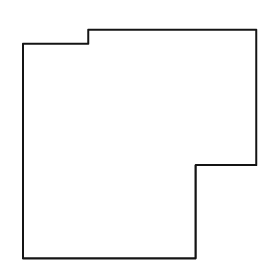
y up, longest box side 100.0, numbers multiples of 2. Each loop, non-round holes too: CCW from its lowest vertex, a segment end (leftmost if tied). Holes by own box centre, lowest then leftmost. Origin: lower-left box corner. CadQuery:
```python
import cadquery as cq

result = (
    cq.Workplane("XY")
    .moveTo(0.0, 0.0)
    .lineTo(74.0, 0.0)
    .lineTo(74.0, 40.0)
    .lineTo(100.0, 40.0)
    .lineTo(100.0, 98.0)
    .lineTo(28.0, 98.0)
    .lineTo(28.0, 92.0)
    .lineTo(0.0, 92.0)
    .close()
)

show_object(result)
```